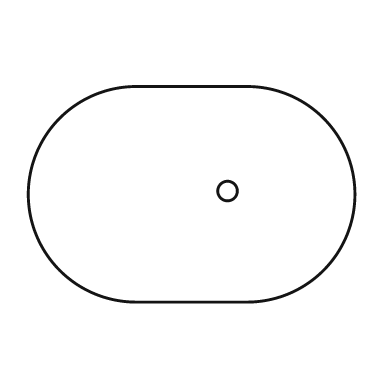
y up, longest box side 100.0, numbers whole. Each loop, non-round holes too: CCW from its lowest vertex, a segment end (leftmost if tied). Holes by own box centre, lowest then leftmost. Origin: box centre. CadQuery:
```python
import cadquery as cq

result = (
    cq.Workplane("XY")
    .moveTo(-17.0, -33.0)
    .lineTo(17.0, -33.0)
    .threePointArc((50.0, 0.0), (17.0, 33.0))
    .lineTo(-17.0, 33.0)
    .threePointArc((-50.0, 0.0), (-17.0, -33.0))
    .close()
    .moveTo(11.0, 1.0)
    .circle(3.0)
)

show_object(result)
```